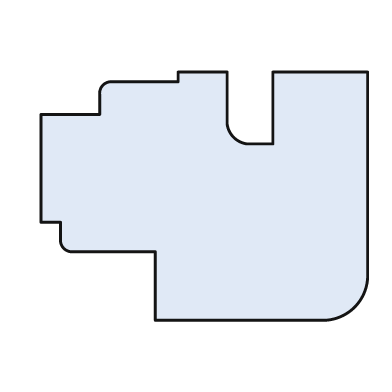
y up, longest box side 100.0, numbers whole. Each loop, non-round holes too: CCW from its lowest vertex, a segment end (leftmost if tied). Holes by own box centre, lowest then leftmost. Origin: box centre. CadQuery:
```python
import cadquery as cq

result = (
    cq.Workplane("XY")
    .moveTo(-15.0, -38.0)
    .lineTo(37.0, -38.0)
    .threePointArc((46.0, -34.0), (50.0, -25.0))
    .lineTo(50.0, 38.0)
    .lineTo(21.0, 38.0)
    .lineTo(21.0, 16.0)
    .lineTo(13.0, 16.0)
    .threePointArc((9.0, 18.0), (7.0, 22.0))
    .lineTo(7.0, 38.0)
    .lineTo(-8.0, 38.0)
    .lineTo(-8.0, 35.0)
    .lineTo(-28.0, 35.0)
    .threePointArc((-31.0, 34.0), (-32.0, 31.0))
    .lineTo(-32.0, 25.0)
    .lineTo(-50.0, 25.0)
    .lineTo(-50.0, -8.0)
    .lineTo(-44.0, -8.0)
    .lineTo(-44.0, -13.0)
    .threePointArc((-43.0, -16.0), (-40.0, -17.0))
    .lineTo(-15.0, -17.0)
    .close()
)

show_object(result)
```